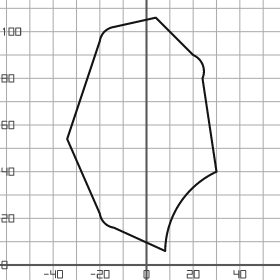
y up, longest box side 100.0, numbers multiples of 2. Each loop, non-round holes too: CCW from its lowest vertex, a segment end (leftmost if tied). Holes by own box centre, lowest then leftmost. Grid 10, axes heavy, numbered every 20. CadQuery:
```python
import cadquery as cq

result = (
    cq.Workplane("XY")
    .moveTo(8.0, 6.0)
    .threePointArc((14.0, 26.0), (30.0, 40.0))
    .lineTo(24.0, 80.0)
    .threePointArc((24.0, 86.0), (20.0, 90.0))
    .lineTo(4.0, 106.0)
    .lineTo(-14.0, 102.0)
    .threePointArc((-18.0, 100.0), (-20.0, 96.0))
    .lineTo(-34.0, 54.0)
    .lineTo(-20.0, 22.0)
    .threePointArc((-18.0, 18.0), (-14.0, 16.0))
    .close()
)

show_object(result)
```